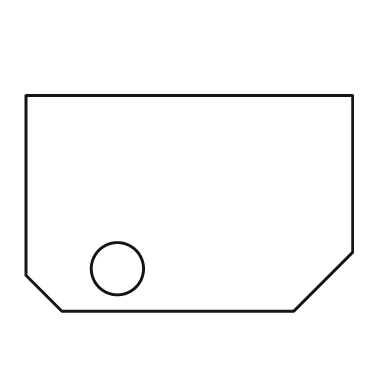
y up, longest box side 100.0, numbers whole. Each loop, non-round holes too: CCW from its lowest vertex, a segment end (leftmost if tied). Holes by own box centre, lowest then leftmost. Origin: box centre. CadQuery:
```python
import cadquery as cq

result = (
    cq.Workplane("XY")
    .moveTo(-39.0, -33.0)
    .lineTo(32.0, -33.0)
    .lineTo(50.0, -15.0)
    .lineTo(50.0, 33.0)
    .lineTo(-50.0, 33.0)
    .lineTo(-50.0, -22.0)
    .close()
    .moveTo(-22.0, -20.0)
    .circle(8.0)
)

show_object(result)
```